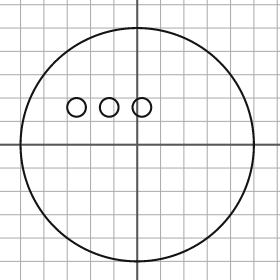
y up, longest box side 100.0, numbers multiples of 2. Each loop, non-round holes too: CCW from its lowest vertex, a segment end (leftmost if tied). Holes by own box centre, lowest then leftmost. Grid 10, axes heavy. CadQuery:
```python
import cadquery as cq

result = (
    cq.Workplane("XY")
    .moveTo(0.0, 0.0)
    .circle(50.0)
    .moveTo(-26.0, 16.0)
    .circle(4.0)
    .moveTo(-12.0, 16.0)
    .circle(4.0)
    .moveTo(2.0, 16.0)
    .circle(4.0)
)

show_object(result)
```